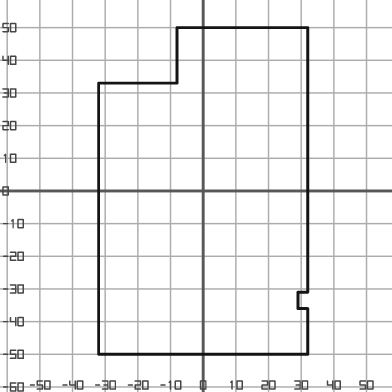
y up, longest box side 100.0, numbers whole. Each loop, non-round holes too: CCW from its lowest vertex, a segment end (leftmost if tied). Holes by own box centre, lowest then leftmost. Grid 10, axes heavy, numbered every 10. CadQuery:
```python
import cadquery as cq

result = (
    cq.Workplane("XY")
    .moveTo(-32.0, -50.0)
    .lineTo(32.0, -50.0)
    .lineTo(32.0, -36.0)
    .lineTo(29.0, -36.0)
    .lineTo(29.0, -31.0)
    .lineTo(32.0, -31.0)
    .lineTo(32.0, 50.0)
    .lineTo(-8.0, 50.0)
    .lineTo(-8.0, 33.0)
    .lineTo(-32.0, 33.0)
    .close()
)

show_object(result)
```